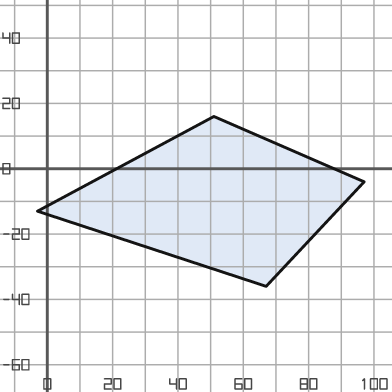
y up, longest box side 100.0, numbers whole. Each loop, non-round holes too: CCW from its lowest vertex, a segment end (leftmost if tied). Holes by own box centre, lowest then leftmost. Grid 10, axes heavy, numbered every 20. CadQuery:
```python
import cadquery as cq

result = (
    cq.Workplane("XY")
    .moveTo(67.0, -36.0)
    .lineTo(97.0, -4.0)
    .lineTo(51.0, 16.0)
    .lineTo(-3.0, -13.0)
    .close()
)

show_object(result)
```